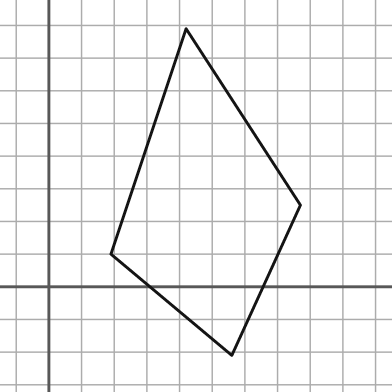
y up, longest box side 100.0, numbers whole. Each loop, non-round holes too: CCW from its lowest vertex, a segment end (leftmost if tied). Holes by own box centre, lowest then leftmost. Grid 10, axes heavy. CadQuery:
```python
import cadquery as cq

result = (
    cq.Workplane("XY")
    .moveTo(56.0, -21.0)
    .lineTo(77.0, 25.0)
    .lineTo(42.0, 79.0)
    .lineTo(19.0, 10.0)
    .close()
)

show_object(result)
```